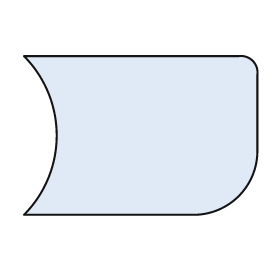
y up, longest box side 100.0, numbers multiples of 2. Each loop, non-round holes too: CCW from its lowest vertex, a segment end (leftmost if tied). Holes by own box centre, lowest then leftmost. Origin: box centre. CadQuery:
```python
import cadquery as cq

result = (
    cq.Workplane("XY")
    .moveTo(-50.0, -34.0)
    .lineTo(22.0, -34.0)
    .threePointArc((42.0, -26.0), (50.0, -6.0))
    .lineTo(50.0, 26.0)
    .threePointArc((48.0, 32.0), (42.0, 34.0))
    .lineTo(-50.0, 34.0)
    .threePointArc((-36.0, 0.0), (-50.0, -34.0))
    .close()
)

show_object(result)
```